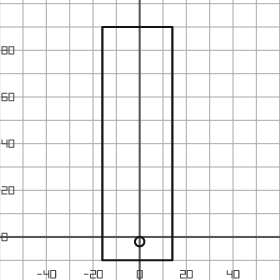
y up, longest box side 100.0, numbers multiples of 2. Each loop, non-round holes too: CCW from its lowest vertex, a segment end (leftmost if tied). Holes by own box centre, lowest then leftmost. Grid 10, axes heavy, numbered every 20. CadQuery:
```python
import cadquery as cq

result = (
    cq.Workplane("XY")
    .moveTo(-16.0, -10.0)
    .lineTo(14.0, -10.0)
    .lineTo(14.0, 90.0)
    .lineTo(-16.0, 90.0)
    .close()
    .moveTo(0.0, -2.0)
    .circle(2.0)
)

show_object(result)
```